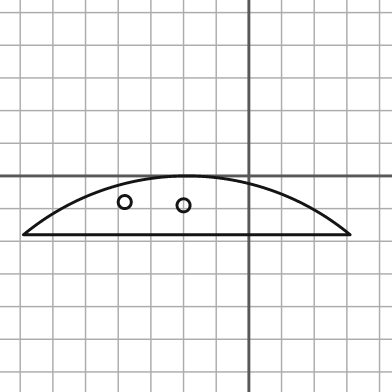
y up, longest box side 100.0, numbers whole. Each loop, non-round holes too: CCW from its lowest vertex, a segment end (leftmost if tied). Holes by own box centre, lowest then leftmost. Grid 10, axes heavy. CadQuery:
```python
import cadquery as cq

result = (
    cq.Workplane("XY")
    .moveTo(-69.0, -18.0)
    .lineTo(31.0, -18.0)
    .threePointArc((-19.0, 0.0), (-69.0, -18.0))
    .close()
    .moveTo(-20.0, -9.0)
    .circle(2.0)
    .moveTo(-38.0, -8.0)
    .circle(2.0)
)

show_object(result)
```